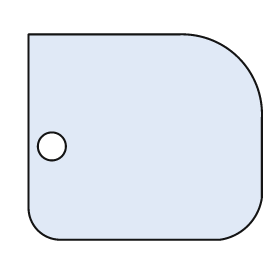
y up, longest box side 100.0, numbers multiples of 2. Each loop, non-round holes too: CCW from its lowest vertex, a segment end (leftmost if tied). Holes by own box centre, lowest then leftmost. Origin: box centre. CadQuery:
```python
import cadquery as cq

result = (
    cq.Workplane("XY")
    .moveTo(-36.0, -44.0)
    .lineTo(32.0, -44.0)
    .threePointArc((44.0, -38.0), (50.0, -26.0))
    .lineTo(50.0, 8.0)
    .threePointArc((40.0, 34.0), (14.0, 44.0))
    .lineTo(-50.0, 44.0)
    .lineTo(-50.0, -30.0)
    .threePointArc((-46.0, -40.0), (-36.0, -44.0))
    .close()
    .moveTo(-40.0, -4.0)
    .circle(6.0)
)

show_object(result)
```